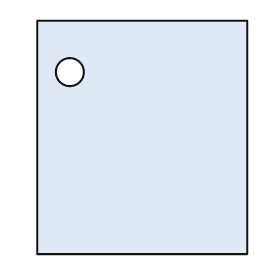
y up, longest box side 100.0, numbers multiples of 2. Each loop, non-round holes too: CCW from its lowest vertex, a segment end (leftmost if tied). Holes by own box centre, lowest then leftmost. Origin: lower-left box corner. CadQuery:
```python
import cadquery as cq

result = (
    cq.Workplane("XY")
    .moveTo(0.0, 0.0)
    .lineTo(90.0, 0.0)
    .lineTo(90.0, 100.0)
    .lineTo(0.0, 100.0)
    .close()
    .moveTo(14.0, 78.0)
    .circle(6.0)
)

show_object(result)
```